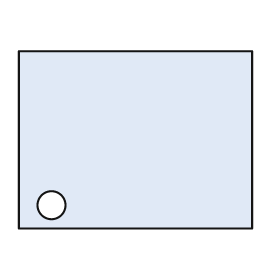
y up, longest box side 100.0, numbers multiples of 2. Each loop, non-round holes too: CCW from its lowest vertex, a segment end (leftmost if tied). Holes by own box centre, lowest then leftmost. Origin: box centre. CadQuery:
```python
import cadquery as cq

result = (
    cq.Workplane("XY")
    .moveTo(-50.0, -38.0)
    .lineTo(50.0, -38.0)
    .lineTo(50.0, 38.0)
    .lineTo(-50.0, 38.0)
    .close()
    .moveTo(-36.0, -28.0)
    .circle(6.0)
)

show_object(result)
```